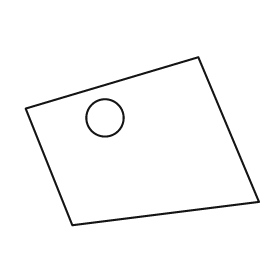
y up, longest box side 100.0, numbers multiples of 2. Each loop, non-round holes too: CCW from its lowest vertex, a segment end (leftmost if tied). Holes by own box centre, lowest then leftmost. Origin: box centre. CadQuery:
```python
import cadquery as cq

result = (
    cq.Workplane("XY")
    .moveTo(-30.0, -36.0)
    .lineTo(50.0, -26.0)
    .lineTo(24.0, 36.0)
    .lineTo(-50.0, 14.0)
    .close()
    .moveTo(-16.0, 10.0)
    .circle(8.0)
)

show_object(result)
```